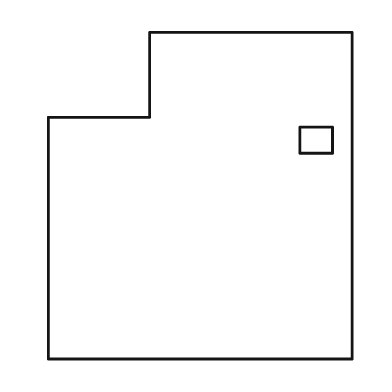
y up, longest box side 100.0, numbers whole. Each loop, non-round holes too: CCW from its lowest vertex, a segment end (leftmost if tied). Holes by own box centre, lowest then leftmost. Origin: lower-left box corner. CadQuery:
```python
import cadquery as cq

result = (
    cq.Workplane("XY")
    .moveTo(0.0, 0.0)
    .lineTo(93.0, 0.0)
    .lineTo(93.0, 100.0)
    .lineTo(31.0, 100.0)
    .lineTo(31.0, 74.0)
    .lineTo(0.0, 74.0)
    .close()
    .moveTo(77.0, 63.0)
    .lineTo(87.0, 63.0)
    .lineTo(87.0, 71.0)
    .lineTo(77.0, 71.0)
    .close()
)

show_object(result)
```